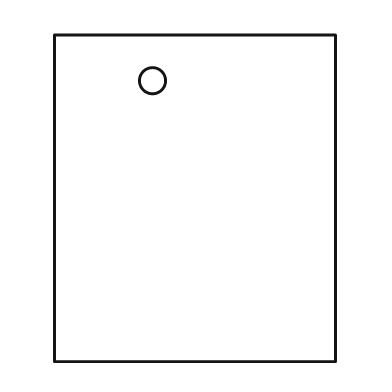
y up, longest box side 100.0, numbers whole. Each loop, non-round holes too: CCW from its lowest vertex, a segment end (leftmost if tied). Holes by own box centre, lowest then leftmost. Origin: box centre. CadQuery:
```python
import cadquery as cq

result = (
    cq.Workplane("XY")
    .moveTo(-43.0, -50.0)
    .lineTo(43.0, -50.0)
    .lineTo(43.0, 50.0)
    .lineTo(-43.0, 50.0)
    .close()
    .moveTo(-13.0, 36.0)
    .circle(4.0)
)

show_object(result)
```